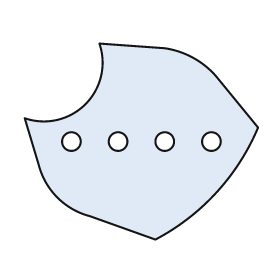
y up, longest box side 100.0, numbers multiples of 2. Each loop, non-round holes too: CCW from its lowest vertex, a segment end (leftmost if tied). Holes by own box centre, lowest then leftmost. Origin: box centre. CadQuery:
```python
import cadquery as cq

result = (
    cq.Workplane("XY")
    .moveTo(6.0, -42.0)
    .threePointArc((32.0, -22.0), (50.0, 6.0))
    .lineTo(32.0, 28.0)
    .threePointArc((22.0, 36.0), (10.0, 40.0))
    .lineTo(-18.0, 42.0)
    .threePointArc((-24.0, 16.0), (-50.0, 10.0))
    .lineTo(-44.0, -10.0)
    .threePointArc((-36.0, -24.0), (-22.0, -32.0))
    .close()
    .moveTo(-30.0, 0.0)
    .circle(4.0)
    .moveTo(-10.0, 0.0)
    .circle(4.0)
    .moveTo(10.0, 0.0)
    .circle(4.0)
    .moveTo(30.0, 0.0)
    .circle(4.0)
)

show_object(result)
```